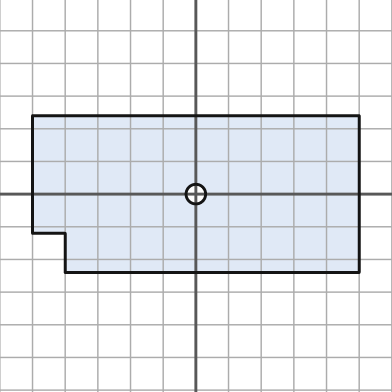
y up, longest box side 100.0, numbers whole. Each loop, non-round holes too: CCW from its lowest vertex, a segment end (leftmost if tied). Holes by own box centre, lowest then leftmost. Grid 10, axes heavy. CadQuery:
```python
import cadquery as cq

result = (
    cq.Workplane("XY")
    .moveTo(-40.0, -24.0)
    .lineTo(50.0, -24.0)
    .lineTo(50.0, 24.0)
    .lineTo(-50.0, 24.0)
    .lineTo(-50.0, -12.0)
    .lineTo(-40.0, -12.0)
    .close()
    .moveTo(0.0, 0.0)
    .circle(3.0)
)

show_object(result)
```